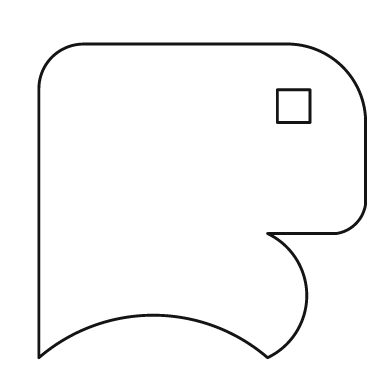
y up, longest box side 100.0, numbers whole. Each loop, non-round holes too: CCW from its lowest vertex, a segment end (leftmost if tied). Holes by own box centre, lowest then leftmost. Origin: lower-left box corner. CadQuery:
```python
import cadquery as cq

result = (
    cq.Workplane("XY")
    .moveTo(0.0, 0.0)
    .threePointArc((35.0, 13.0), (70.0, 0.0))
    .threePointArc((82.0, 19.0), (70.0, 38.0))
    .lineTo(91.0, 38.0)
    .threePointArc((97.0, 41.0), (100.0, 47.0))
    .lineTo(100.0, 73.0)
    .threePointArc((93.0, 89.0), (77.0, 96.0))
    .lineTo(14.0, 96.0)
    .threePointArc((4.0, 92.0), (0.0, 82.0))
    .close()
    .moveTo(73.0, 72.0)
    .lineTo(83.0, 72.0)
    .lineTo(83.0, 82.0)
    .lineTo(73.0, 82.0)
    .close()
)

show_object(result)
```